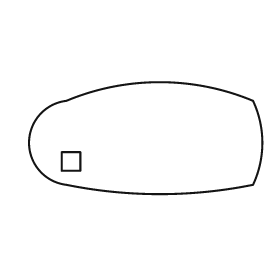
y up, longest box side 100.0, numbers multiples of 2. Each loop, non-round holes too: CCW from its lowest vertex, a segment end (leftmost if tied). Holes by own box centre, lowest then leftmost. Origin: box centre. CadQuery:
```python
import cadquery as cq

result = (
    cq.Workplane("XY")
    .moveTo(-34.0, -20.0)
    .threePointArc((6.0, -24.0), (46.0, -20.0))
    .threePointArc((50.0, -2.0), (46.0, 16.0))
    .threePointArc((6.0, 24.0), (-34.0, 16.0))
    .threePointArc((-50.0, -2.0), (-34.0, -20.0))
    .close()
    .moveTo(-36.0, -14.0)
    .lineTo(-28.0, -14.0)
    .lineTo(-28.0, -6.0)
    .lineTo(-36.0, -6.0)
    .close()
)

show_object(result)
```